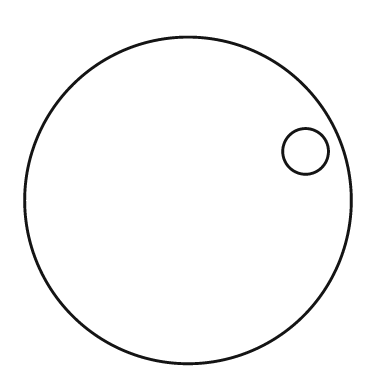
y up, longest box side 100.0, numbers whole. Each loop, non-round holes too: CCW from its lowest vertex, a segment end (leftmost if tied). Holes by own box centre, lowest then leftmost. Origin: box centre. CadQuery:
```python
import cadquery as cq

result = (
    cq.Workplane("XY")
    .moveTo(0.0, 0.0)
    .circle(50.0)
    .moveTo(36.0, 15.0)
    .circle(7.0)
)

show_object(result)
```